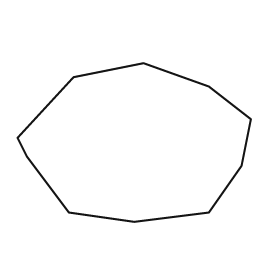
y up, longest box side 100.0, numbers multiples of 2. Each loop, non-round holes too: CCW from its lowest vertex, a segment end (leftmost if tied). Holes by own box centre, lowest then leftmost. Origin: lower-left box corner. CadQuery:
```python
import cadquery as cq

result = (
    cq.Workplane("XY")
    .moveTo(50.0, 0.0)
    .lineTo(82.0, 4.0)
    .lineTo(96.0, 24.0)
    .lineTo(100.0, 44.0)
    .lineTo(82.0, 58.0)
    .lineTo(54.0, 68.0)
    .lineTo(24.0, 62.0)
    .lineTo(0.0, 36.0)
    .lineTo(4.0, 28.0)
    .lineTo(22.0, 4.0)
    .close()
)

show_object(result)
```